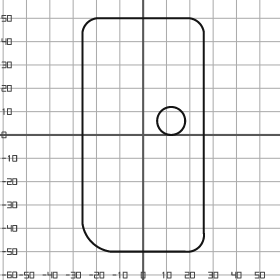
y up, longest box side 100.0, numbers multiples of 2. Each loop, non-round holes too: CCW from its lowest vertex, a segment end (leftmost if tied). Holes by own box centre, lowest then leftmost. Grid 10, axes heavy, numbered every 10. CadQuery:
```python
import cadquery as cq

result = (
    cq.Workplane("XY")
    .moveTo(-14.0, -50.0)
    .lineTo(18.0, -50.0)
    .threePointArc((24.0, -48.0), (26.0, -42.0))
    .lineTo(26.0, 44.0)
    .threePointArc((24.0, 48.0), (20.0, 50.0))
    .lineTo(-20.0, 50.0)
    .threePointArc((-24.0, 48.0), (-26.0, 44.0))
    .lineTo(-26.0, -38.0)
    .threePointArc((-22.0, -46.0), (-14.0, -50.0))
    .close()
    .moveTo(12.0, 6.0)
    .circle(6.0)
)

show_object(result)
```